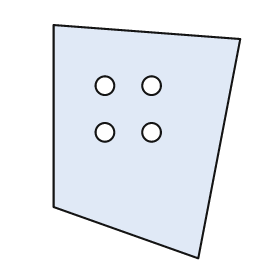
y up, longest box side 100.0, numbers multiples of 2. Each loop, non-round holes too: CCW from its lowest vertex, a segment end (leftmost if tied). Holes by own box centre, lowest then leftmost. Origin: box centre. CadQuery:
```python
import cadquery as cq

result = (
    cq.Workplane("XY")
    .moveTo(22.0, -50.0)
    .lineTo(40.0, 44.0)
    .lineTo(-40.0, 50.0)
    .lineTo(-40.0, -28.0)
    .close()
    .moveTo(-18.0, 4.0)
    .circle(4.0)
    .moveTo(2.0, 4.0)
    .circle(4.0)
    .moveTo(-18.0, 24.0)
    .circle(4.0)
    .moveTo(2.0, 24.0)
    .circle(4.0)
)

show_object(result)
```